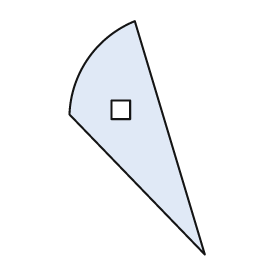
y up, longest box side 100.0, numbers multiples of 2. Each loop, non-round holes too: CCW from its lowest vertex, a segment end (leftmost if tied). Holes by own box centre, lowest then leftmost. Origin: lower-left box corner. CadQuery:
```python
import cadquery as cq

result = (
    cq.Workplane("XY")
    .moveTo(58.0, 0.0)
    .lineTo(28.0, 100.0)
    .threePointArc((8.0, 84.0), (0.0, 60.0))
    .close()
    .moveTo(18.0, 58.0)
    .lineTo(26.0, 58.0)
    .lineTo(26.0, 66.0)
    .lineTo(18.0, 66.0)
    .close()
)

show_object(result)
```